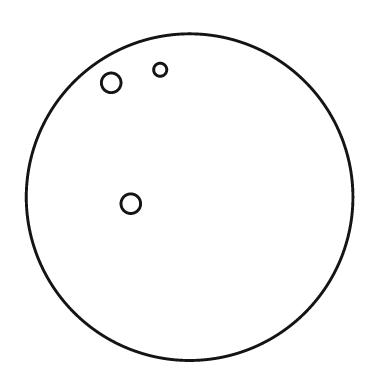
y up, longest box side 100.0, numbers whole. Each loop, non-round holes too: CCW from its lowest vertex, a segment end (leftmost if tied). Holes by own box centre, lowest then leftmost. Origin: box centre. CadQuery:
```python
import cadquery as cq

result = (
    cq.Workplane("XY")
    .moveTo(0.0, 0.0)
    .circle(50.0)
    .moveTo(-18.0, -2.0)
    .circle(3.0)
    .moveTo(-24.0, 35.0)
    .circle(3.0)
    .moveTo(-9.0, 39.0)
    .circle(2.0)
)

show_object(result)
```